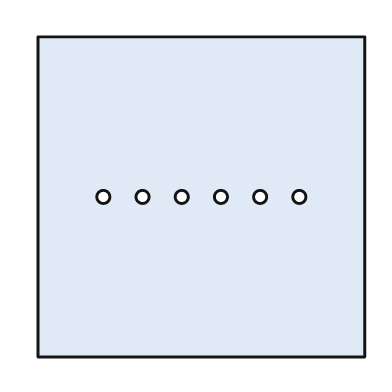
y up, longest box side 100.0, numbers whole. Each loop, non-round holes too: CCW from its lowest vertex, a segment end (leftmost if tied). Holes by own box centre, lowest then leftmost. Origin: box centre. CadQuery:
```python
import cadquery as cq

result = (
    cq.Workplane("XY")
    .moveTo(-50.0, -49.0)
    .lineTo(50.0, -49.0)
    .lineTo(50.0, 49.0)
    .lineTo(-50.0, 49.0)
    .close()
    .moveTo(-30.0, 0.0)
    .circle(2.0)
    .moveTo(-18.0, 0.0)
    .circle(2.0)
    .moveTo(-6.0, 0.0)
    .circle(2.0)
    .moveTo(6.0, 0.0)
    .circle(2.0)
    .moveTo(18.0, 0.0)
    .circle(2.0)
    .moveTo(30.0, 0.0)
    .circle(2.0)
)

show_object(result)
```